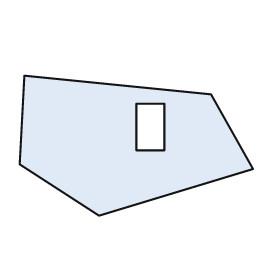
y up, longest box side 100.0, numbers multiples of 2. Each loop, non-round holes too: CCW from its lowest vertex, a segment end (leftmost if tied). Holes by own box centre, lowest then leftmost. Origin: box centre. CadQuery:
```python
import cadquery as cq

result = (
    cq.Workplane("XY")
    .moveTo(-16.0, -30.0)
    .lineTo(50.0, -10.0)
    .lineTo(32.0, 22.0)
    .lineTo(-48.0, 30.0)
    .lineTo(-50.0, -8.0)
    .close()
    .moveTo(0.0, -2.0)
    .lineTo(12.0, -2.0)
    .lineTo(12.0, 18.0)
    .lineTo(0.0, 18.0)
    .close()
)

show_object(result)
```